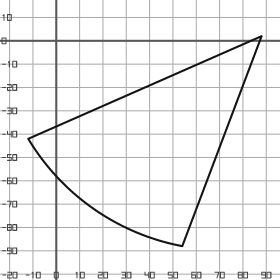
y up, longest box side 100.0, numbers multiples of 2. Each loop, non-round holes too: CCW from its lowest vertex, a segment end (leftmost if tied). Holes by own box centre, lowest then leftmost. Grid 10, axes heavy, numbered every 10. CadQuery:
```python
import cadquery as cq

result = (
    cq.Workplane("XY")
    .moveTo(54.0, -88.0)
    .lineTo(88.0, 2.0)
    .lineTo(-12.0, -42.0)
    .threePointArc((16.0, -72.0), (54.0, -88.0))
    .close()
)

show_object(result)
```